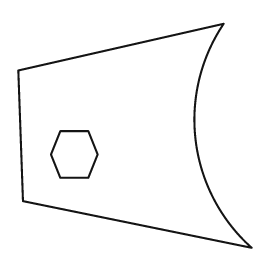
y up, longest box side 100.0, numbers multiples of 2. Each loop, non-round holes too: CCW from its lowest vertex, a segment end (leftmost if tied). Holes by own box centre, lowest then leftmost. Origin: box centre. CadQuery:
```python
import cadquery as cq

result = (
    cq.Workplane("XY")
    .moveTo(50.0, -48.0)
    .threePointArc((26.0, -2.0), (38.0, 48.0))
    .lineTo(-50.0, 28.0)
    .lineTo(-48.0, -28.0)
    .close()
    .moveTo(-32.0, -18.0)
    .lineTo(-20.0, -18.0)
    .lineTo(-16.0, -8.0)
    .lineTo(-20.0, 2.0)
    .lineTo(-32.0, 2.0)
    .lineTo(-36.0, -8.0)
    .close()
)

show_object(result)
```